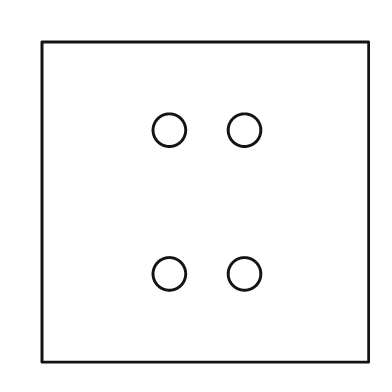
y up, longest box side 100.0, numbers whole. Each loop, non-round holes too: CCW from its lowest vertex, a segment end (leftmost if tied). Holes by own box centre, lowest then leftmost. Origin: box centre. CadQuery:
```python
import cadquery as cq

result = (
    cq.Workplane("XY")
    .moveTo(-50.0, -49.0)
    .lineTo(50.0, -49.0)
    .lineTo(50.0, 49.0)
    .lineTo(-50.0, 49.0)
    .close()
    .moveTo(-11.0, -22.0)
    .circle(5.0)
    .moveTo(12.0, -22.0)
    .circle(5.0)
    .moveTo(-11.0, 22.0)
    .circle(5.0)
    .moveTo(12.0, 22.0)
    .circle(5.0)
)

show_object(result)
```